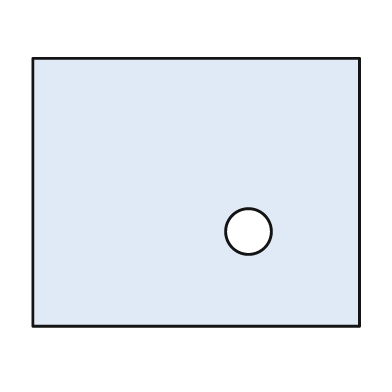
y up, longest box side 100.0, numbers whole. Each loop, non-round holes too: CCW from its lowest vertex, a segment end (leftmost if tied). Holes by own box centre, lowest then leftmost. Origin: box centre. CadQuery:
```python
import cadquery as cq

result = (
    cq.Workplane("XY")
    .moveTo(-50.0, -41.0)
    .lineTo(50.0, -41.0)
    .lineTo(50.0, 41.0)
    .lineTo(-50.0, 41.0)
    .close()
    .moveTo(16.0, -12.0)
    .circle(7.0)
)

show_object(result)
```